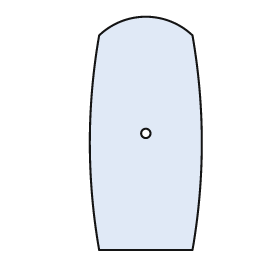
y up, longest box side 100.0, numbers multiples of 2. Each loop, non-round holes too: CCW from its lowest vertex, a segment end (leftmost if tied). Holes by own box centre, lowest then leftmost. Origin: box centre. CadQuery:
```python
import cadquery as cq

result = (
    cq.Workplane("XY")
    .moveTo(-20.0, -50.0)
    .lineTo(20.0, -50.0)
    .threePointArc((24.0, -4.0), (20.0, 42.0))
    .threePointArc((0.0, 50.0), (-20.0, 42.0))
    .threePointArc((-24.0, -4.0), (-20.0, -50.0))
    .close()
    .moveTo(0.0, 0.0)
    .circle(2.0)
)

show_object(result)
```